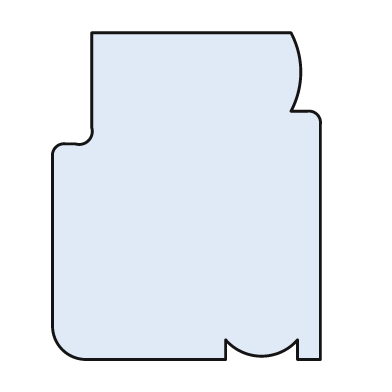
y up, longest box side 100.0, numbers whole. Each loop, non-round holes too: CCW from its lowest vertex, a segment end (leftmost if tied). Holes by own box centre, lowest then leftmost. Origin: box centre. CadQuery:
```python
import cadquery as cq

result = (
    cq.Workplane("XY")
    .moveTo(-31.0, -50.0)
    .lineTo(12.0, -50.0)
    .lineTo(12.0, -44.0)
    .threePointArc((23.0, -49.0), (34.0, -44.0))
    .lineTo(34.0, -50.0)
    .lineTo(41.0, -50.0)
    .lineTo(41.0, 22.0)
    .threePointArc((40.0, 25.0), (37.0, 26.0))
    .lineTo(32.0, 26.0)
    .threePointArc((35.0, 38.0), (32.0, 50.0))
    .lineTo(-29.0, 50.0)
    .lineTo(-29.0, 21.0)
    .threePointArc((-30.0, 17.0), (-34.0, 16.0))
    .lineTo(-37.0, 16.0)
    .threePointArc((-40.0, 15.0), (-41.0, 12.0))
    .lineTo(-41.0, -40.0)
    .threePointArc((-38.0, -47.0), (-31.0, -50.0))
    .close()
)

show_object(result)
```